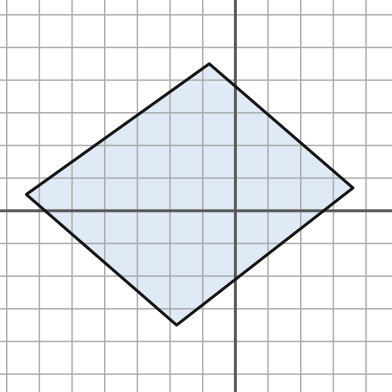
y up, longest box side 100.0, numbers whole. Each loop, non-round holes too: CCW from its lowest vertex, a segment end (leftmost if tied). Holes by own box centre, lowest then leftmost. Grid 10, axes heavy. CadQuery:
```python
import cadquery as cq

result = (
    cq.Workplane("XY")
    .moveTo(-18.0, -35.0)
    .lineTo(36.0, 7.0)
    .lineTo(-8.0, 45.0)
    .lineTo(-64.0, 5.0)
    .close()
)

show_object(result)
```